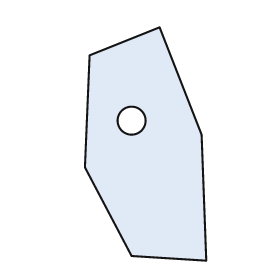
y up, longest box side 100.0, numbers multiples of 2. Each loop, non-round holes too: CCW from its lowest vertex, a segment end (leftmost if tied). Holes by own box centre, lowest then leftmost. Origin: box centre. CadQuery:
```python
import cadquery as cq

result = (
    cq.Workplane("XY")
    .moveTo(26.0, -50.0)
    .lineTo(24.0, 4.0)
    .lineTo(6.0, 50.0)
    .lineTo(-24.0, 38.0)
    .lineTo(-26.0, -10.0)
    .lineTo(-6.0, -48.0)
    .close()
    .moveTo(-6.0, 10.0)
    .circle(6.0)
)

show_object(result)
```